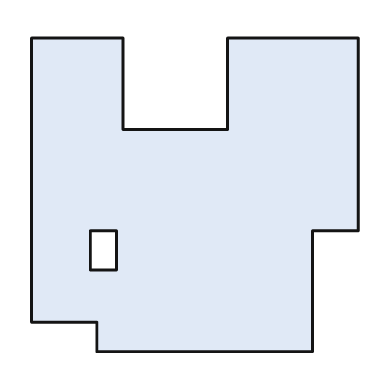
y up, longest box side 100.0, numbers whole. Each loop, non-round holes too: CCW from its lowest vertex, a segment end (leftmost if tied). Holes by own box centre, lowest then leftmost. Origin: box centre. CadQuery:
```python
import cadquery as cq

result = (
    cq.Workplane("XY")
    .moveTo(-30.0, -48.0)
    .lineTo(36.0, -48.0)
    .lineTo(36.0, -11.0)
    .lineTo(50.0, -11.0)
    .lineTo(50.0, 48.0)
    .lineTo(10.0, 48.0)
    .lineTo(10.0, 20.0)
    .lineTo(-22.0, 20.0)
    .lineTo(-22.0, 48.0)
    .lineTo(-50.0, 48.0)
    .lineTo(-50.0, -39.0)
    .lineTo(-30.0, -39.0)
    .close()
    .moveTo(-32.0, -23.0)
    .lineTo(-24.0, -23.0)
    .lineTo(-24.0, -11.0)
    .lineTo(-32.0, -11.0)
    .close()
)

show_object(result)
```